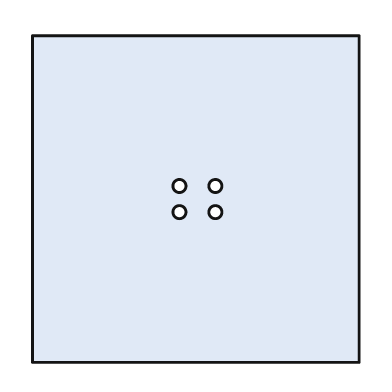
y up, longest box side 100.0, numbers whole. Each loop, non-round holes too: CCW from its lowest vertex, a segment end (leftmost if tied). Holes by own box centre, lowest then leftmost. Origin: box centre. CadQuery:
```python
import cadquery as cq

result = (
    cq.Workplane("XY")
    .moveTo(-50.0, -50.0)
    .lineTo(50.0, -50.0)
    .lineTo(50.0, 50.0)
    .lineTo(-50.0, 50.0)
    .close()
    .moveTo(-5.0, -4.0)
    .circle(2.0)
    .moveTo(6.0, -4.0)
    .circle(2.0)
    .moveTo(-5.0, 4.0)
    .circle(2.0)
    .moveTo(6.0, 4.0)
    .circle(2.0)
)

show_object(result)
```